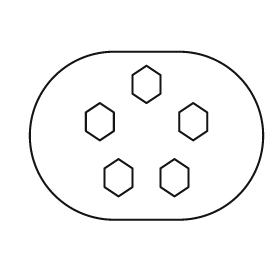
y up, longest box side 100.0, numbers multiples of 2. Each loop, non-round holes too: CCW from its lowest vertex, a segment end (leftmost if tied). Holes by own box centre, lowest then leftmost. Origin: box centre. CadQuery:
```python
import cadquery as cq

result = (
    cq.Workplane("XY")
    .moveTo(-14.0, -36.0)
    .lineTo(14.0, -36.0)
    .threePointArc((50.0, 0.0), (14.0, 36.0))
    .lineTo(-14.0, 36.0)
    .threePointArc((-50.0, 0.0), (-14.0, -36.0))
    .close()
    .moveTo(-12.0, -26.0)
    .lineTo(-6.0, -22.0)
    .lineTo(-6.0, -14.0)
    .lineTo(-12.0, -10.0)
    .lineTo(-18.0, -14.0)
    .lineTo(-18.0, -22.0)
    .close()
    .moveTo(12.0, -26.0)
    .lineTo(18.0, -22.0)
    .lineTo(18.0, -14.0)
    .lineTo(12.0, -10.0)
    .lineTo(6.0, -14.0)
    .lineTo(6.0, -22.0)
    .close()
    .moveTo(-20.0, -2.0)
    .lineTo(-14.0, 2.0)
    .lineTo(-14.0, 10.0)
    .lineTo(-20.0, 14.0)
    .lineTo(-26.0, 10.0)
    .lineTo(-26.0, 2.0)
    .close()
    .moveTo(20.0, -2.0)
    .lineTo(26.0, 2.0)
    .lineTo(26.0, 10.0)
    .lineTo(20.0, 14.0)
    .lineTo(14.0, 10.0)
    .lineTo(14.0, 2.0)
    .close()
    .moveTo(0.0, 14.0)
    .lineTo(6.0, 18.0)
    .lineTo(6.0, 26.0)
    .lineTo(0.0, 30.0)
    .lineTo(-6.0, 26.0)
    .lineTo(-6.0, 18.0)
    .close()
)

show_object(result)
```